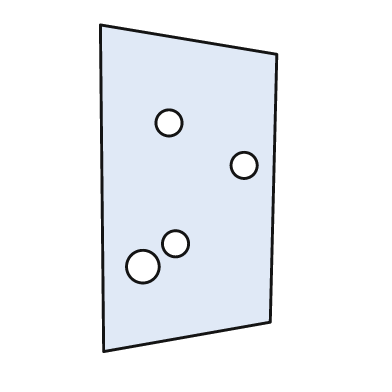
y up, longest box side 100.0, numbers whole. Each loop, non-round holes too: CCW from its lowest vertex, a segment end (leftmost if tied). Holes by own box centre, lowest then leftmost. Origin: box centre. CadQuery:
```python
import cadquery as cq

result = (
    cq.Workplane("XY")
    .moveTo(-26.0, -50.0)
    .lineTo(25.0, -41.0)
    .lineTo(27.0, 41.0)
    .lineTo(-27.0, 50.0)
    .close()
    .moveTo(-14.0, -24.0)
    .circle(5.0)
    .moveTo(-4.0, -17.0)
    .circle(4.0)
    .moveTo(17.0, 7.0)
    .circle(4.0)
    .moveTo(-6.0, 20.0)
    .circle(4.0)
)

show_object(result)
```